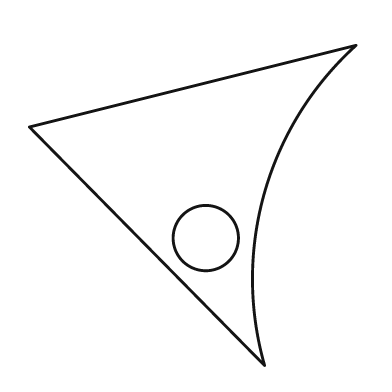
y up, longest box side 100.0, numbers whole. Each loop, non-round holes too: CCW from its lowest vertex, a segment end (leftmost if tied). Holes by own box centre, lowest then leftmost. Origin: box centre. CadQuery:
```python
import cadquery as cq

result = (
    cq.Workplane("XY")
    .moveTo(22.0, -49.0)
    .threePointArc((22.0, 4.0), (50.0, 49.0))
    .lineTo(-50.0, 24.0)
    .close()
    .moveTo(4.0, -10.0)
    .circle(10.0)
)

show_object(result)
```